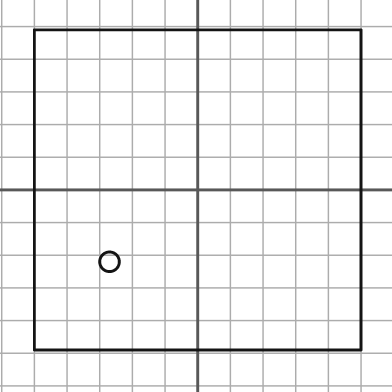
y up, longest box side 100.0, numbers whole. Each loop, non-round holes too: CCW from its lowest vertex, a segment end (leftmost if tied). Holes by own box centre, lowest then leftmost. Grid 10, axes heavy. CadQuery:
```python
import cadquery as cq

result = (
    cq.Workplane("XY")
    .moveTo(-50.0, -49.0)
    .lineTo(50.0, -49.0)
    .lineTo(50.0, 49.0)
    .lineTo(-50.0, 49.0)
    .close()
    .moveTo(-27.0, -22.0)
    .circle(3.0)
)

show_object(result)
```